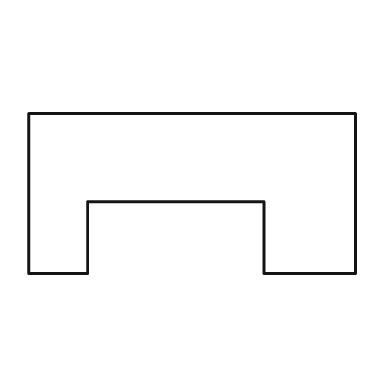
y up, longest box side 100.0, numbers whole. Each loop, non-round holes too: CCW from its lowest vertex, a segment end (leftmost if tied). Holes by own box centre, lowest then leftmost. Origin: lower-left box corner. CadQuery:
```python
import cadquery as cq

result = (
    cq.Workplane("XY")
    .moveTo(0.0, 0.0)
    .lineTo(18.0, 0.0)
    .lineTo(18.0, 22.0)
    .lineTo(72.0, 22.0)
    .lineTo(72.0, 0.0)
    .lineTo(100.0, 0.0)
    .lineTo(100.0, 49.0)
    .lineTo(0.0, 49.0)
    .close()
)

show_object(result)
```